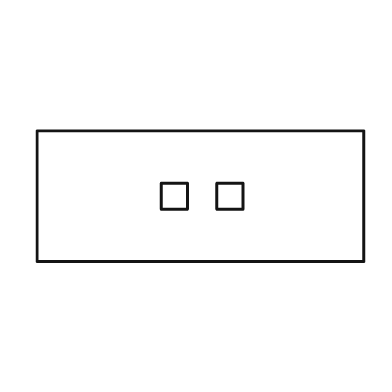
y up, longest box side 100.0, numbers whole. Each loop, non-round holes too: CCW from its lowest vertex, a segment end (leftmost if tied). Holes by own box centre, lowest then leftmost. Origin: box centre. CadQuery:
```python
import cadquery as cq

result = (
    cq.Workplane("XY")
    .moveTo(-50.0, -20.0)
    .lineTo(50.0, -20.0)
    .lineTo(50.0, 20.0)
    .lineTo(-50.0, 20.0)
    .close()
    .moveTo(-12.0, -4.0)
    .lineTo(-4.0, -4.0)
    .lineTo(-4.0, 4.0)
    .lineTo(-12.0, 4.0)
    .close()
    .moveTo(5.0, -4.0)
    .lineTo(13.0, -4.0)
    .lineTo(13.0, 4.0)
    .lineTo(5.0, 4.0)
    .close()
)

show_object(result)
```